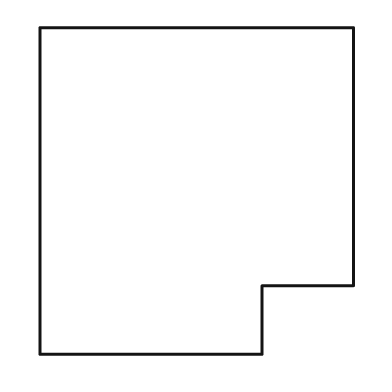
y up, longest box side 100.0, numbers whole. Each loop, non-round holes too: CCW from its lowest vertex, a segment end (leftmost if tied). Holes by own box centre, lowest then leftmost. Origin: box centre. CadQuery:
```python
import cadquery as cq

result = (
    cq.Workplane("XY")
    .moveTo(-48.0, -50.0)
    .lineTo(20.0, -50.0)
    .lineTo(20.0, -29.0)
    .lineTo(48.0, -29.0)
    .lineTo(48.0, 50.0)
    .lineTo(-48.0, 50.0)
    .close()
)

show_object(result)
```